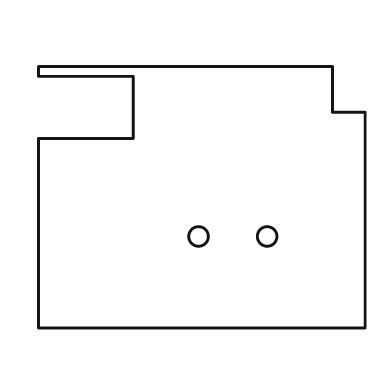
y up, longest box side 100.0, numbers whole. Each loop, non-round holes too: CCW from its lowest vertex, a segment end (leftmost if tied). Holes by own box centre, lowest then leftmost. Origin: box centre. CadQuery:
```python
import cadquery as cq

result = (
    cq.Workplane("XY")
    .moveTo(-50.0, -40.0)
    .lineTo(50.0, -40.0)
    .lineTo(50.0, 26.0)
    .lineTo(40.0, 26.0)
    .lineTo(40.0, 40.0)
    .lineTo(-50.0, 40.0)
    .lineTo(-50.0, 37.0)
    .lineTo(-21.0, 37.0)
    .lineTo(-21.0, 18.0)
    .lineTo(-50.0, 18.0)
    .close()
    .moveTo(-1.0, -12.0)
    .circle(3.0)
    .moveTo(20.0, -12.0)
    .circle(3.0)
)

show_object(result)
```